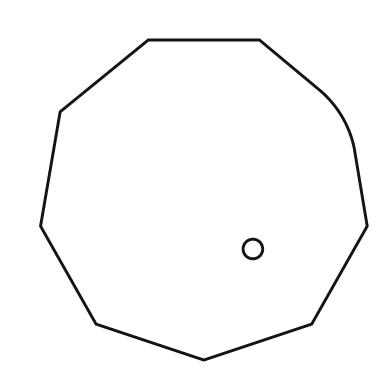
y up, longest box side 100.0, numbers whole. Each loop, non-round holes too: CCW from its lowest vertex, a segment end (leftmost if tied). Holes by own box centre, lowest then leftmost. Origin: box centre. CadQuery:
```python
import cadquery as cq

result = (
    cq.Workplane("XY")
    .moveTo(0.0, -49.0)
    .lineTo(33.0, -38.0)
    .lineTo(50.0, -8.0)
    .lineTo(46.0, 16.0)
    .threePointArc((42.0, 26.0), (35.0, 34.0))
    .lineTo(17.0, 49.0)
    .lineTo(-17.0, 49.0)
    .lineTo(-44.0, 27.0)
    .lineTo(-50.0, -8.0)
    .lineTo(-33.0, -38.0)
    .close()
    .moveTo(15.0, -15.0)
    .circle(3.0)
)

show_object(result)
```